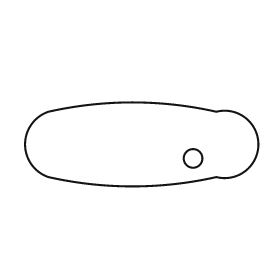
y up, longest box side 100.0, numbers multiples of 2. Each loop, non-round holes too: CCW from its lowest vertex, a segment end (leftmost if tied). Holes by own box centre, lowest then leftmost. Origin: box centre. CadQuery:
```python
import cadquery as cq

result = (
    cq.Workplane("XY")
    .moveTo(-40.0, -14.0)
    .threePointArc((-4.0, -18.0), (32.0, -14.0))
    .threePointArc((50.0, 0.0), (32.0, 14.0))
    .threePointArc((-4.0, 18.0), (-40.0, 14.0))
    .threePointArc((-50.0, 0.0), (-40.0, -14.0))
    .close()
    .moveTo(22.0, -6.0)
    .circle(4.0)
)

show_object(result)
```